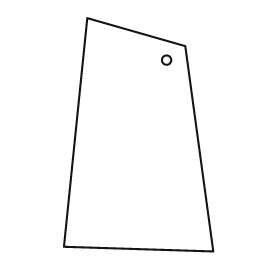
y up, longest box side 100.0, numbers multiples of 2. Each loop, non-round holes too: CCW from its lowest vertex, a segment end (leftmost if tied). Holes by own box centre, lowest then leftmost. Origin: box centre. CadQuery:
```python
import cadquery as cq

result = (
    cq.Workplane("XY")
    .moveTo(32.0, -50.0)
    .lineTo(20.0, 38.0)
    .lineTo(-22.0, 50.0)
    .lineTo(-32.0, -48.0)
    .close()
    .moveTo(12.0, 32.0)
    .circle(2.0)
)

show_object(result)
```